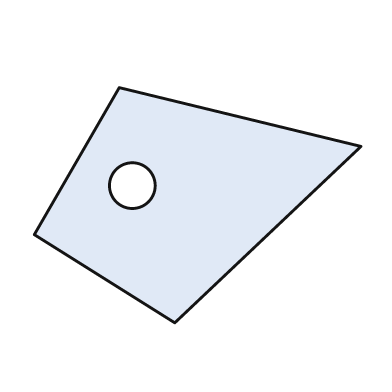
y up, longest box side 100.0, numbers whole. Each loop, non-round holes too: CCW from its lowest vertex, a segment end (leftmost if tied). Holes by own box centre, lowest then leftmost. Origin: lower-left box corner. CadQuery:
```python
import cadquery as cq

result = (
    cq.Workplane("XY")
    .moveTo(43.0, 0.0)
    .lineTo(100.0, 54.0)
    .lineTo(26.0, 72.0)
    .lineTo(0.0, 27.0)
    .close()
    .moveTo(30.0, 42.0)
    .circle(7.0)
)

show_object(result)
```